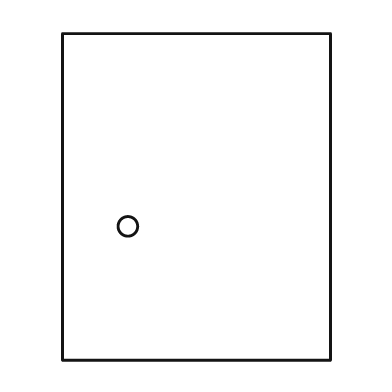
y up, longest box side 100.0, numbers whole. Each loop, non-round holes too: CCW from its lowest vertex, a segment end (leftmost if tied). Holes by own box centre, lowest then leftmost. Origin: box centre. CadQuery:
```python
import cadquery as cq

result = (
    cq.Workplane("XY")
    .moveTo(-41.0, -50.0)
    .lineTo(41.0, -50.0)
    .lineTo(41.0, 50.0)
    .lineTo(-41.0, 50.0)
    .close()
    .moveTo(-21.0, -9.0)
    .circle(3.0)
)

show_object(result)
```